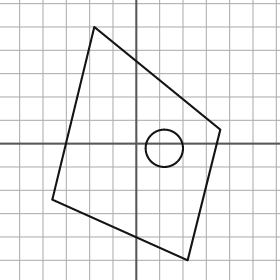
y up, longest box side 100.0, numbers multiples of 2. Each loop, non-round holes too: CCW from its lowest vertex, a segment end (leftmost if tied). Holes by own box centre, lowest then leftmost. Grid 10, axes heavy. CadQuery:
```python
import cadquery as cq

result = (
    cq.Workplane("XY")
    .moveTo(22.0, -50.0)
    .lineTo(36.0, 6.0)
    .lineTo(-18.0, 50.0)
    .lineTo(-36.0, -24.0)
    .close()
    .moveTo(12.0, -2.0)
    .circle(8.0)
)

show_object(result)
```